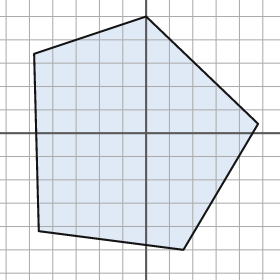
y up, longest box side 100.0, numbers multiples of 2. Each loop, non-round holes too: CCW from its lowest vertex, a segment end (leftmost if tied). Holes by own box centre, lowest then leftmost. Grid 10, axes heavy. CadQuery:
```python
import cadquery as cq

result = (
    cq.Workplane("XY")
    .moveTo(16.0, -50.0)
    .lineTo(48.0, 4.0)
    .lineTo(0.0, 50.0)
    .lineTo(-48.0, 34.0)
    .lineTo(-46.0, -42.0)
    .close()
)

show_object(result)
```